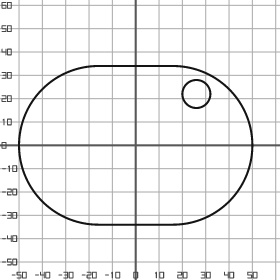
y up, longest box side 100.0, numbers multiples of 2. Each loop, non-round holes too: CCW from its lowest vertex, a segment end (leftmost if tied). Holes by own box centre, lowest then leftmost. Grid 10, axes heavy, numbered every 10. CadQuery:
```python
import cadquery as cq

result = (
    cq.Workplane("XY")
    .moveTo(-16.0, -34.0)
    .lineTo(16.0, -34.0)
    .threePointArc((50.0, 0.0), (16.0, 34.0))
    .lineTo(-16.0, 34.0)
    .threePointArc((-50.0, 0.0), (-16.0, -34.0))
    .close()
    .moveTo(26.0, 22.0)
    .circle(6.0)
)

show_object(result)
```